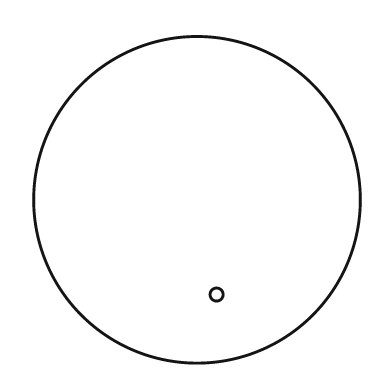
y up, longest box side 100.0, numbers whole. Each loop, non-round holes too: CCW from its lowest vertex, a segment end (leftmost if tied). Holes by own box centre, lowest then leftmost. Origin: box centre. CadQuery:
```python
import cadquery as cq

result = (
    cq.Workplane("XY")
    .moveTo(0.0, 0.0)
    .circle(50.0)
    .moveTo(6.0, -29.0)
    .circle(2.0)
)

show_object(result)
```